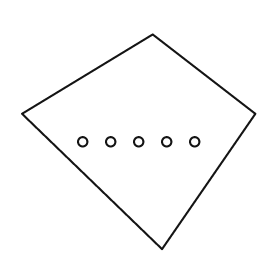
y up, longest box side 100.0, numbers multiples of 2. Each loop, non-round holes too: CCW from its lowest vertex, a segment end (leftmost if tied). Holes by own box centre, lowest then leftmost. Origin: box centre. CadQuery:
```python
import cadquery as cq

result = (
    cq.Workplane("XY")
    .moveTo(10.0, -46.0)
    .lineTo(50.0, 12.0)
    .lineTo(6.0, 46.0)
    .lineTo(-50.0, 12.0)
    .close()
    .moveTo(-24.0, 0.0)
    .circle(2.0)
    .moveTo(-12.0, 0.0)
    .circle(2.0)
    .moveTo(0.0, 0.0)
    .circle(2.0)
    .moveTo(12.0, 0.0)
    .circle(2.0)
    .moveTo(24.0, 0.0)
    .circle(2.0)
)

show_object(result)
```